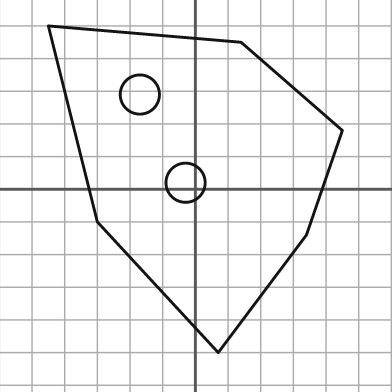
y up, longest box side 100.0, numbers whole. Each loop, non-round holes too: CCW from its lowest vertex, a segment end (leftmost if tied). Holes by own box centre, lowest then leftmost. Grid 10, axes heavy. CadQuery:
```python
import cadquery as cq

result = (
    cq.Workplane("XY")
    .moveTo(7.0, -50.0)
    .lineTo(34.0, -14.0)
    .lineTo(45.0, 18.0)
    .lineTo(14.0, 45.0)
    .lineTo(-45.0, 50.0)
    .lineTo(-30.0, -10.0)
    .close()
    .moveTo(-3.0, 2.0)
    .circle(6.0)
    .moveTo(-17.0, 29.0)
    .circle(6.0)
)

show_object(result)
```